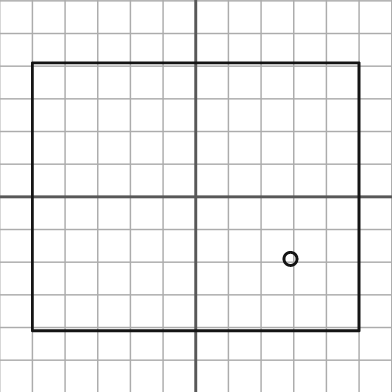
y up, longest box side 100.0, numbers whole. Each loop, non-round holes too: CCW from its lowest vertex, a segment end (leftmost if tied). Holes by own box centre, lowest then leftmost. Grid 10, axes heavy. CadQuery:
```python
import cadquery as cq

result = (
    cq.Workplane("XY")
    .moveTo(-50.0, -41.0)
    .lineTo(50.0, -41.0)
    .lineTo(50.0, 41.0)
    .lineTo(-50.0, 41.0)
    .close()
    .moveTo(29.0, -19.0)
    .circle(2.0)
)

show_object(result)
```